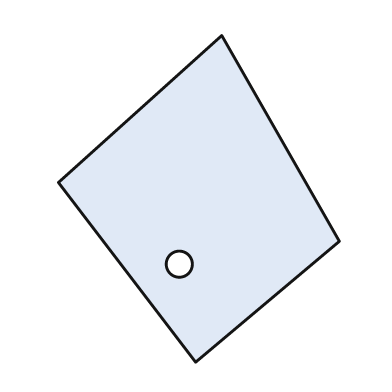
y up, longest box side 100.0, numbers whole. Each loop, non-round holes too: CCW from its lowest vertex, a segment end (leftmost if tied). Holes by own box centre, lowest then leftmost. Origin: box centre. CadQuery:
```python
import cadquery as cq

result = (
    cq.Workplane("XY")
    .moveTo(-1.0, -50.0)
    .lineTo(43.0, -13.0)
    .lineTo(7.0, 50.0)
    .lineTo(-43.0, 5.0)
    .close()
    .moveTo(-6.0, -20.0)
    .circle(4.0)
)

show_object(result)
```